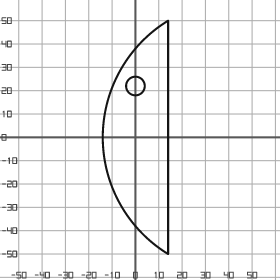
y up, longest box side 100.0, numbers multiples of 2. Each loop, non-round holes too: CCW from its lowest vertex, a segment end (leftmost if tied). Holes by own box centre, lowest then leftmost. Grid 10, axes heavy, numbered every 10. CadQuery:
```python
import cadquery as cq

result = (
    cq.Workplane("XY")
    .moveTo(14.0, -50.0)
    .lineTo(14.0, 50.0)
    .threePointArc((-14.0, 0.0), (14.0, -50.0))
    .close()
    .moveTo(0.0, 22.0)
    .circle(4.0)
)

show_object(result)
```